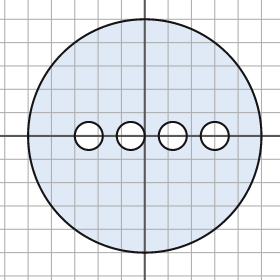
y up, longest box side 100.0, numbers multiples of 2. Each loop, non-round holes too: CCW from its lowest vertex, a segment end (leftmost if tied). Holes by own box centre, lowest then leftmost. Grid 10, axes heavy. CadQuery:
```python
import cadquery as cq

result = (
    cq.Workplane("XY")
    .moveTo(0.0, 0.0)
    .circle(50.0)
    .moveTo(-24.0, 0.0)
    .circle(6.0)
    .moveTo(-6.0, 0.0)
    .circle(6.0)
    .moveTo(12.0, 0.0)
    .circle(6.0)
    .moveTo(30.0, 0.0)
    .circle(6.0)
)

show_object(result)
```